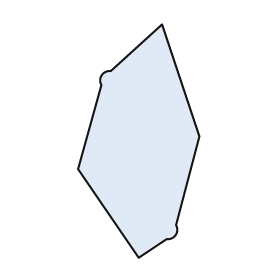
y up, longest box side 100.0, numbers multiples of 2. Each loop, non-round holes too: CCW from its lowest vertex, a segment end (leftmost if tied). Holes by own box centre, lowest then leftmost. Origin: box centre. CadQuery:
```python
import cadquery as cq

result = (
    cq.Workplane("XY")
    .moveTo(0.0, -50.0)
    .lineTo(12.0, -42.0)
    .threePointArc((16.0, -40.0), (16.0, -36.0))
    .lineTo(26.0, 2.0)
    .lineTo(10.0, 50.0)
    .lineTo(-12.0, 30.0)
    .threePointArc((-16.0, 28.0), (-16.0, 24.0))
    .lineTo(-26.0, -12.0)
    .close()
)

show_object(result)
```